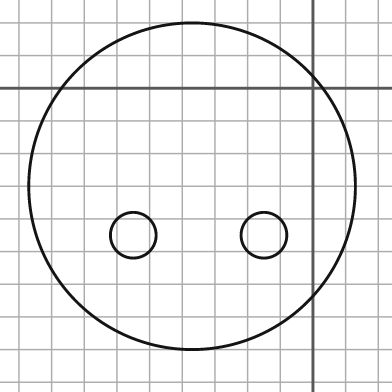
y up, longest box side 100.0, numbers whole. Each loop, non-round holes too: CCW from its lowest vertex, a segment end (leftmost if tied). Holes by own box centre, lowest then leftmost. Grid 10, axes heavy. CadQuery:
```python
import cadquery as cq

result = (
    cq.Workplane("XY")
    .moveTo(-37.0, -30.0)
    .circle(50.0)
    .moveTo(-55.0, -45.0)
    .circle(7.0)
    .moveTo(-15.0, -45.0)
    .circle(7.0)
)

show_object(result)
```